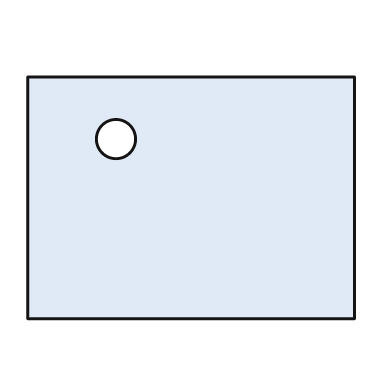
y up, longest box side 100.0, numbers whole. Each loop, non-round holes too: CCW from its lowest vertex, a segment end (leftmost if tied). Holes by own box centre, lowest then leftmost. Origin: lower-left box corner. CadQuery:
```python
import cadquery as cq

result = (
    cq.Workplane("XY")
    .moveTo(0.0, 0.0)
    .lineTo(100.0, 0.0)
    .lineTo(100.0, 74.0)
    .lineTo(0.0, 74.0)
    .close()
    .moveTo(27.0, 55.0)
    .circle(6.0)
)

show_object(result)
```